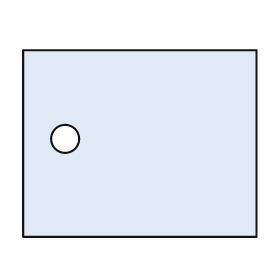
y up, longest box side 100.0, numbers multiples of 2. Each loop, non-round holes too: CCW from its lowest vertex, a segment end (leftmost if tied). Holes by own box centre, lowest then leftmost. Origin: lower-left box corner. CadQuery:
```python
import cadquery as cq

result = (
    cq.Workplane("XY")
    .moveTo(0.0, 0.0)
    .lineTo(100.0, 0.0)
    .lineTo(100.0, 80.0)
    .lineTo(0.0, 80.0)
    .close()
    .moveTo(18.0, 42.0)
    .circle(6.0)
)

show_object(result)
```